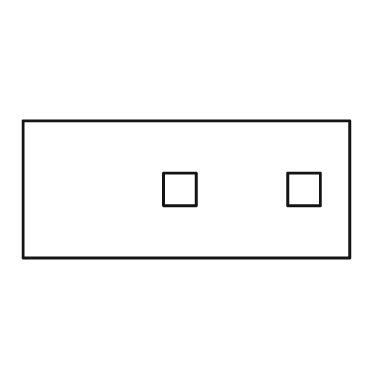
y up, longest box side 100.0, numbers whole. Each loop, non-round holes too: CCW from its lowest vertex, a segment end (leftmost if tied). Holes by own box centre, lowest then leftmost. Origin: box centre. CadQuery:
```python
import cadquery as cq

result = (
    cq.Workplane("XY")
    .moveTo(-50.0, -21.0)
    .lineTo(50.0, -21.0)
    .lineTo(50.0, 21.0)
    .lineTo(-50.0, 21.0)
    .close()
    .moveTo(-7.0, -5.0)
    .lineTo(3.0, -5.0)
    .lineTo(3.0, 5.0)
    .lineTo(-7.0, 5.0)
    .close()
    .moveTo(31.0, -5.0)
    .lineTo(41.0, -5.0)
    .lineTo(41.0, 5.0)
    .lineTo(31.0, 5.0)
    .close()
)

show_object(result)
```